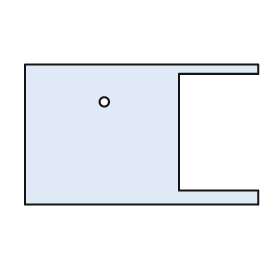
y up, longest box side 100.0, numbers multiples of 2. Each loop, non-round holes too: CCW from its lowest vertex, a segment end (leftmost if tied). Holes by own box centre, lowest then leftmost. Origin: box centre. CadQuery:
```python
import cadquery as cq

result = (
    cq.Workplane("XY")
    .moveTo(-50.0, -30.0)
    .lineTo(50.0, -30.0)
    .lineTo(50.0, -24.0)
    .lineTo(16.0, -24.0)
    .lineTo(16.0, 26.0)
    .lineTo(50.0, 26.0)
    .lineTo(50.0, 30.0)
    .lineTo(-50.0, 30.0)
    .close()
    .moveTo(-16.0, 14.0)
    .circle(2.0)
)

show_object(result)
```